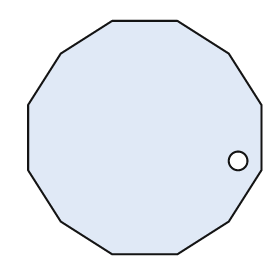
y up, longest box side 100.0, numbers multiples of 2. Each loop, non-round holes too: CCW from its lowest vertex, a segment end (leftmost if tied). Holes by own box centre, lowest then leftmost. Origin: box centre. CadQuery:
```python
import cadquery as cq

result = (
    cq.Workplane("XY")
    .moveTo(-14.0, -50.0)
    .lineTo(14.0, -50.0)
    .lineTo(36.0, -36.0)
    .lineTo(50.0, -14.0)
    .lineTo(50.0, 14.0)
    .lineTo(36.0, 36.0)
    .lineTo(14.0, 50.0)
    .lineTo(-14.0, 50.0)
    .lineTo(-36.0, 36.0)
    .lineTo(-50.0, 14.0)
    .lineTo(-50.0, -14.0)
    .lineTo(-36.0, -36.0)
    .close()
    .moveTo(40.0, -10.0)
    .circle(4.0)
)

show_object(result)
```